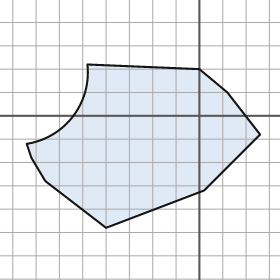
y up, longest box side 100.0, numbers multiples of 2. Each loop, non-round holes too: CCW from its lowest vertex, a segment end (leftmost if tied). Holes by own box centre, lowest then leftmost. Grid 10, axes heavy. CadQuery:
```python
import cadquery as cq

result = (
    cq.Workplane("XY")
    .moveTo(-40.0, -48.0)
    .lineTo(2.0, -32.0)
    .lineTo(26.0, -8.0)
    .lineTo(12.0, 10.0)
    .lineTo(0.0, 20.0)
    .lineTo(-48.0, 22.0)
    .threePointArc((-54.0, 0.0), (-74.0, -12.0))
    .lineTo(-72.0, -18.0)
    .lineTo(-66.0, -28.0)
    .close()
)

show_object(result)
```